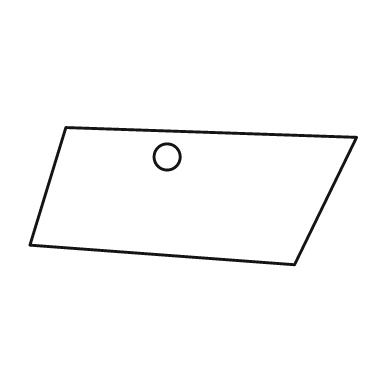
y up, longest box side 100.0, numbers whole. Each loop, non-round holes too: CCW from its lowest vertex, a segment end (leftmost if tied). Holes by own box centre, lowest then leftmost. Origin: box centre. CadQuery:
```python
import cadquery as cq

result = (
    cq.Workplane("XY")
    .moveTo(31.0, -21.0)
    .lineTo(50.0, 18.0)
    .lineTo(-39.0, 21.0)
    .lineTo(-50.0, -15.0)
    .close()
    .moveTo(-8.0, 12.0)
    .circle(4.0)
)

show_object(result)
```